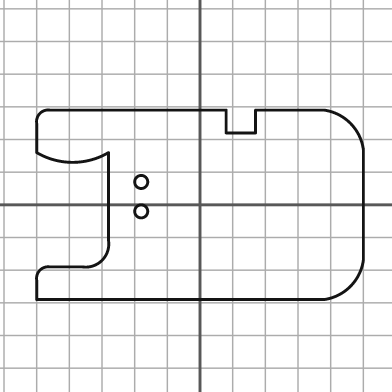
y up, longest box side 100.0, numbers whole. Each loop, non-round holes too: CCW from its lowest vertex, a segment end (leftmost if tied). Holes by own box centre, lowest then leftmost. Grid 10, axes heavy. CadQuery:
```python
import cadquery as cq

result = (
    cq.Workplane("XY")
    .moveTo(-50.0, -29.0)
    .lineTo(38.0, -29.0)
    .threePointArc((46.0, -25.0), (50.0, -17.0))
    .lineTo(50.0, 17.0)
    .threePointArc((46.0, 25.0), (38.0, 29.0))
    .lineTo(17.0, 29.0)
    .lineTo(17.0, 22.0)
    .lineTo(8.0, 22.0)
    .lineTo(8.0, 29.0)
    .lineTo(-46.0, 29.0)
    .threePointArc((-49.0, 28.0), (-50.0, 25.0))
    .lineTo(-50.0, 16.0)
    .threePointArc((-39.0, 13.0), (-28.0, 16.0))
    .lineTo(-28.0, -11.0)
    .threePointArc((-30.0, -17.0), (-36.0, -19.0))
    .lineTo(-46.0, -19.0)
    .threePointArc((-49.0, -20.0), (-50.0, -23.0))
    .close()
    .moveTo(-18.0, -2.0)
    .circle(2.0)
    .moveTo(-18.0, 7.0)
    .circle(2.0)
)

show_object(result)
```